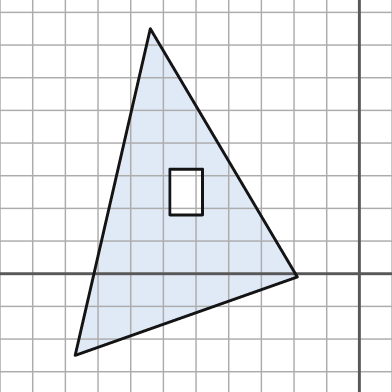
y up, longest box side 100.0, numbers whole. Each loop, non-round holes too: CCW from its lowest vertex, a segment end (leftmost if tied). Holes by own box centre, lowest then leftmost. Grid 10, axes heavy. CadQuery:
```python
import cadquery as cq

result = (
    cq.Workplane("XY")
    .moveTo(-87.0, -25.0)
    .lineTo(-19.0, -1.0)
    .lineTo(-64.0, 75.0)
    .close()
    .moveTo(-58.0, 18.0)
    .lineTo(-48.0, 18.0)
    .lineTo(-48.0, 32.0)
    .lineTo(-58.0, 32.0)
    .close()
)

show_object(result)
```